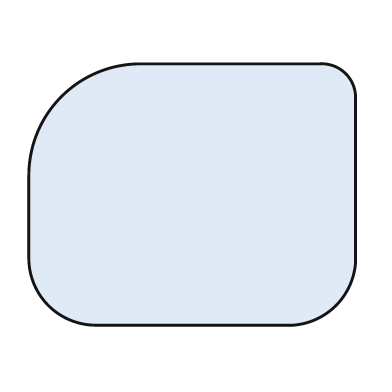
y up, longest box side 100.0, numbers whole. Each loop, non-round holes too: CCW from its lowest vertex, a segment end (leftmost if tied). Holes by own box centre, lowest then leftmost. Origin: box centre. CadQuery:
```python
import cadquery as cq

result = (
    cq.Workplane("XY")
    .moveTo(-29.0, -40.0)
    .lineTo(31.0, -40.0)
    .threePointArc((44.0, -34.0), (50.0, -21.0))
    .lineTo(50.0, 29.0)
    .threePointArc((47.0, 37.0), (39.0, 40.0))
    .lineTo(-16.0, 40.0)
    .threePointArc((-40.0, 30.0), (-50.0, 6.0))
    .lineTo(-50.0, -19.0)
    .threePointArc((-44.0, -34.0), (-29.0, -40.0))
    .close()
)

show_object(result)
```